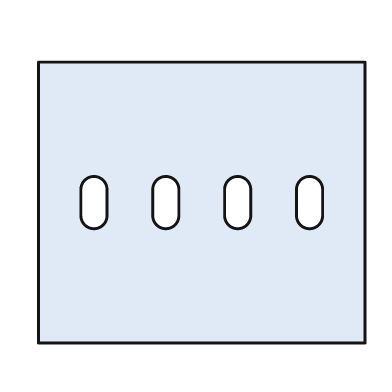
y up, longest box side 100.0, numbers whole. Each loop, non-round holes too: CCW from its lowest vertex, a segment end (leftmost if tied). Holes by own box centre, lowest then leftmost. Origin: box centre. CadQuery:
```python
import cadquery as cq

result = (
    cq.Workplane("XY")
    .moveTo(-50.0, -43.0)
    .lineTo(50.0, -43.0)
    .lineTo(50.0, 43.0)
    .lineTo(-50.0, 43.0)
    .close()
    .moveTo(-37.0, -4.0)
    .threePointArc((-33.0, -8.0), (-29.0, -4.0))
    .lineTo(-29.0, 4.0)
    .threePointArc((-33.0, 8.0), (-37.0, 4.0))
    .close()
    .moveTo(-15.0, -4.0)
    .threePointArc((-11.0, -8.0), (-7.0, -4.0))
    .lineTo(-7.0, 4.0)
    .threePointArc((-11.0, 8.0), (-15.0, 4.0))
    .close()
    .moveTo(7.0, -4.0)
    .threePointArc((11.0, -8.0), (15.0, -4.0))
    .lineTo(15.0, 4.0)
    .threePointArc((11.0, 8.0), (7.0, 4.0))
    .close()
    .moveTo(29.0, -4.0)
    .threePointArc((33.0, -8.0), (37.0, -4.0))
    .lineTo(37.0, 4.0)
    .threePointArc((33.0, 8.0), (29.0, 4.0))
    .close()
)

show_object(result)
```